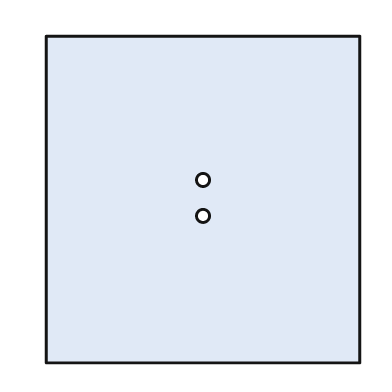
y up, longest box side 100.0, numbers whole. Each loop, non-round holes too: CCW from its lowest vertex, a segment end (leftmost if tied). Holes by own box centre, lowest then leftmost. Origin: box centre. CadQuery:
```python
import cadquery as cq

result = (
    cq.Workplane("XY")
    .moveTo(-48.0, -50.0)
    .lineTo(48.0, -50.0)
    .lineTo(48.0, 50.0)
    .lineTo(-48.0, 50.0)
    .close()
    .moveTo(0.0, -5.0)
    .circle(2.0)
    .moveTo(0.0, 6.0)
    .circle(2.0)
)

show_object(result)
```